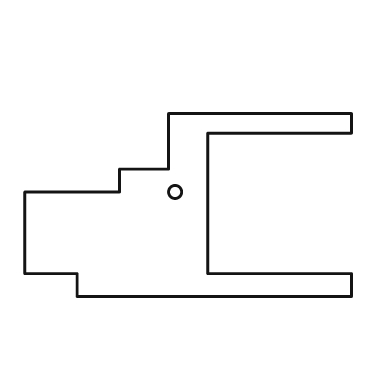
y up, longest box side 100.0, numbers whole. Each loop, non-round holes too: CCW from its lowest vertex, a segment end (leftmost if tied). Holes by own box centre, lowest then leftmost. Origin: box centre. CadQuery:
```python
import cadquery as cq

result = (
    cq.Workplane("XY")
    .moveTo(-34.0, -28.0)
    .lineTo(50.0, -28.0)
    .lineTo(50.0, -21.0)
    .lineTo(6.0, -21.0)
    .lineTo(6.0, 22.0)
    .lineTo(50.0, 22.0)
    .lineTo(50.0, 28.0)
    .lineTo(-6.0, 28.0)
    .lineTo(-6.0, 11.0)
    .lineTo(-21.0, 11.0)
    .lineTo(-21.0, 4.0)
    .lineTo(-50.0, 4.0)
    .lineTo(-50.0, -21.0)
    .lineTo(-34.0, -21.0)
    .close()
    .moveTo(-4.0, 4.0)
    .circle(2.0)
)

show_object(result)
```